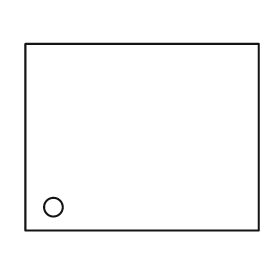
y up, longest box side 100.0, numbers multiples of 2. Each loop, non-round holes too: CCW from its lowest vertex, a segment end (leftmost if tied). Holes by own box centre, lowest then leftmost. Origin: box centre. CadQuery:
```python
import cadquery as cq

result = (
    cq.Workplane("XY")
    .moveTo(-50.0, -40.0)
    .lineTo(50.0, -40.0)
    .lineTo(50.0, 40.0)
    .lineTo(-50.0, 40.0)
    .close()
    .moveTo(-38.0, -30.0)
    .circle(4.0)
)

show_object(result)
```